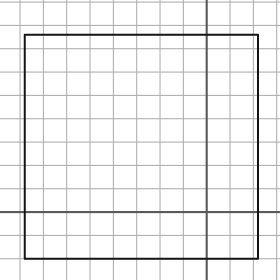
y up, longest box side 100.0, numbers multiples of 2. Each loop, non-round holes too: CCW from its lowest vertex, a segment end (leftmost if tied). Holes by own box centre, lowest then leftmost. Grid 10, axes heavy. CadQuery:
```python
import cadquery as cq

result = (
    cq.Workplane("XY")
    .moveTo(-78.0, -20.0)
    .lineTo(22.0, -20.0)
    .lineTo(22.0, 76.0)
    .lineTo(-78.0, 76.0)
    .close()
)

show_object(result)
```